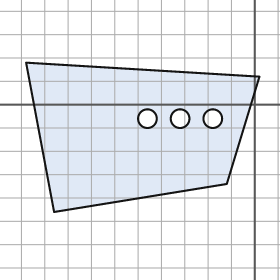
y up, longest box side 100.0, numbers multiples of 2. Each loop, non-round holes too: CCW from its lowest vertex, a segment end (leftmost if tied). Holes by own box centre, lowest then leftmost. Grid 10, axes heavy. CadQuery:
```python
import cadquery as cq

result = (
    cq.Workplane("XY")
    .moveTo(-86.0, -46.0)
    .lineTo(-12.0, -34.0)
    .lineTo(2.0, 12.0)
    .lineTo(-98.0, 18.0)
    .close()
    .moveTo(-46.0, -6.0)
    .circle(4.0)
    .moveTo(-32.0, -6.0)
    .circle(4.0)
    .moveTo(-18.0, -6.0)
    .circle(4.0)
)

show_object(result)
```